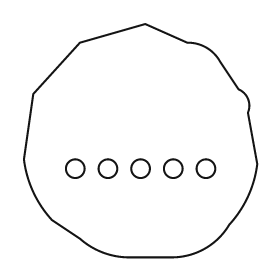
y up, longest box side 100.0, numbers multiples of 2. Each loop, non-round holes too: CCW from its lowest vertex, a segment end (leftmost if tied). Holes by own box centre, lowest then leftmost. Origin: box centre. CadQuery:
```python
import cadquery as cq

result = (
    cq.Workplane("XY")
    .moveTo(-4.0, -50.0)
    .lineTo(14.0, -50.0)
    .threePointArc((28.0, -46.0), (38.0, -36.0))
    .threePointArc((46.0, -24.0), (50.0, -10.0))
    .lineTo(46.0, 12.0)
    .threePointArc((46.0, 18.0), (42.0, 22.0))
    .lineTo(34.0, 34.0)
    .threePointArc((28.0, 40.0), (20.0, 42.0))
    .lineTo(2.0, 50.0)
    .lineTo(-26.0, 42.0)
    .lineTo(-46.0, 20.0)
    .lineTo(-50.0, -8.0)
    .threePointArc((-46.0, -22.0), (-38.0, -34.0))
    .lineTo(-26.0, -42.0)
    .threePointArc((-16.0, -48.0), (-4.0, -50.0))
    .close()
    .moveTo(-28.0, -12.0)
    .circle(4.0)
    .moveTo(-14.0, -12.0)
    .circle(4.0)
    .moveTo(0.0, -12.0)
    .circle(4.0)
    .moveTo(14.0, -12.0)
    .circle(4.0)
    .moveTo(28.0, -12.0)
    .circle(4.0)
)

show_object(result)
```